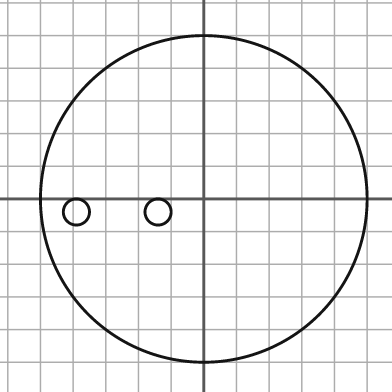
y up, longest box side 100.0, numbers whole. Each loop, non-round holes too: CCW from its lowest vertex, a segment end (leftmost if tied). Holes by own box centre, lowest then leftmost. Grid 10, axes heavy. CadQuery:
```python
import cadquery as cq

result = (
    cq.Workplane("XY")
    .moveTo(0.0, 0.0)
    .circle(50.0)
    .moveTo(-39.0, -4.0)
    .circle(4.0)
    .moveTo(-14.0, -4.0)
    .circle(4.0)
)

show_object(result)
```